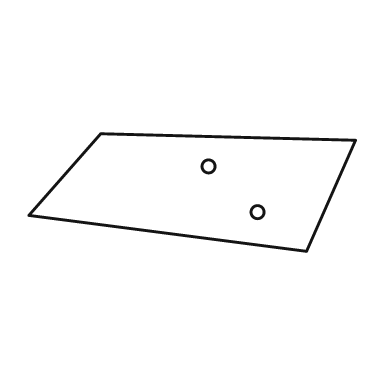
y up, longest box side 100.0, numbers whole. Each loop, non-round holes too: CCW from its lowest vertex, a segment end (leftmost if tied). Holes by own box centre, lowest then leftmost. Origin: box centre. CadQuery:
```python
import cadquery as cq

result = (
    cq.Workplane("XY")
    .moveTo(35.0, -18.0)
    .lineTo(50.0, 16.0)
    .lineTo(-28.0, 18.0)
    .lineTo(-50.0, -7.0)
    .close()
    .moveTo(20.0, -6.0)
    .circle(2.0)
    .moveTo(5.0, 8.0)
    .circle(2.0)
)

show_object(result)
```